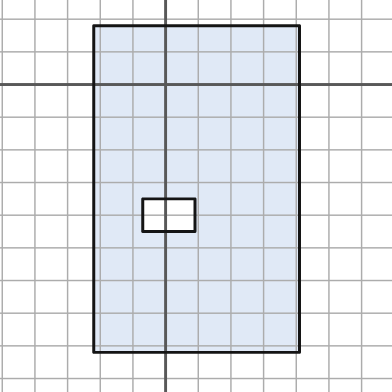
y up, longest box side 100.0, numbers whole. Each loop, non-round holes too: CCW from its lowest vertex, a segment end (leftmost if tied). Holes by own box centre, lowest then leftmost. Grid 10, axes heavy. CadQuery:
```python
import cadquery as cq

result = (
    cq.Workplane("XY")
    .moveTo(-22.0, -82.0)
    .lineTo(41.0, -82.0)
    .lineTo(41.0, 18.0)
    .lineTo(-22.0, 18.0)
    .close()
    .moveTo(-7.0, -45.0)
    .lineTo(9.0, -45.0)
    .lineTo(9.0, -35.0)
    .lineTo(-7.0, -35.0)
    .close()
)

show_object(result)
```